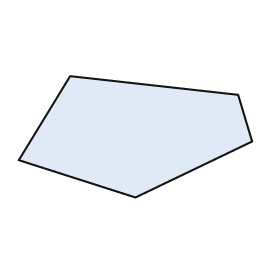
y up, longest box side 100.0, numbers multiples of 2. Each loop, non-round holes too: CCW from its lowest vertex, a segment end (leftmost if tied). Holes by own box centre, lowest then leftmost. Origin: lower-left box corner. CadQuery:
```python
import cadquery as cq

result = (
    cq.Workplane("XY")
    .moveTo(50.0, 0.0)
    .lineTo(100.0, 24.0)
    .lineTo(94.0, 44.0)
    .lineTo(22.0, 52.0)
    .lineTo(0.0, 16.0)
    .close()
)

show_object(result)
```